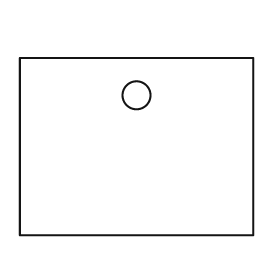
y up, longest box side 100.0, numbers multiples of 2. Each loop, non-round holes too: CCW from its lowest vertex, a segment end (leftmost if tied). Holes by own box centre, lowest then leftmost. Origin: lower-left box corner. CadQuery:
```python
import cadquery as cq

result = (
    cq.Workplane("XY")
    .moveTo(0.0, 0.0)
    .lineTo(100.0, 0.0)
    .lineTo(100.0, 76.0)
    .lineTo(0.0, 76.0)
    .close()
    .moveTo(50.0, 60.0)
    .circle(6.0)
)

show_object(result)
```